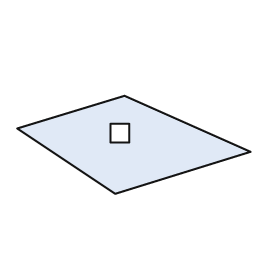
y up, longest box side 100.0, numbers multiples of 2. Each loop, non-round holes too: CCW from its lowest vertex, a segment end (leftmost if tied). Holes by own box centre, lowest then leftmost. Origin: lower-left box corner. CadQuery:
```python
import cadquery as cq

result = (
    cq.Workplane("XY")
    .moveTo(42.0, 0.0)
    .lineTo(100.0, 18.0)
    .lineTo(46.0, 42.0)
    .lineTo(0.0, 28.0)
    .close()
    .moveTo(40.0, 22.0)
    .lineTo(48.0, 22.0)
    .lineTo(48.0, 30.0)
    .lineTo(40.0, 30.0)
    .close()
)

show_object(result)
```